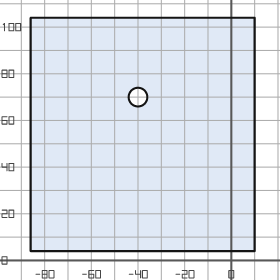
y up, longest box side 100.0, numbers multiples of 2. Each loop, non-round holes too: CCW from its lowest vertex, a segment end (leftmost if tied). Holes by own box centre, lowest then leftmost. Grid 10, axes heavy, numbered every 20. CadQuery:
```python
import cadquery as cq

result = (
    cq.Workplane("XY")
    .moveTo(-86.0, 4.0)
    .lineTo(10.0, 4.0)
    .lineTo(10.0, 104.0)
    .lineTo(-86.0, 104.0)
    .close()
    .moveTo(-40.0, 70.0)
    .circle(4.0)
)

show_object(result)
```